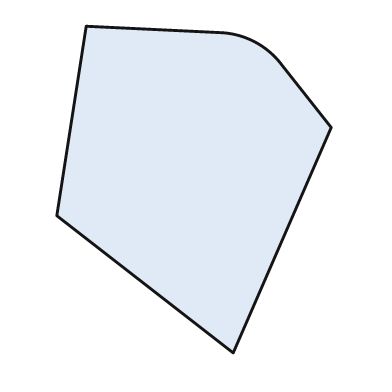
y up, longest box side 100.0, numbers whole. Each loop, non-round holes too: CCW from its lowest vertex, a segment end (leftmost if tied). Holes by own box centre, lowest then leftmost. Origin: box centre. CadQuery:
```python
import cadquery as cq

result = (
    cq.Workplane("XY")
    .moveTo(12.0, -50.0)
    .lineTo(42.0, 19.0)
    .lineTo(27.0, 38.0)
    .threePointArc((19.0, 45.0), (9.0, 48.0))
    .lineTo(-33.0, 50.0)
    .lineTo(-42.0, -8.0)
    .close()
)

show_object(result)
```